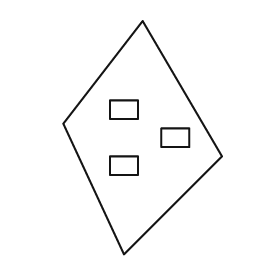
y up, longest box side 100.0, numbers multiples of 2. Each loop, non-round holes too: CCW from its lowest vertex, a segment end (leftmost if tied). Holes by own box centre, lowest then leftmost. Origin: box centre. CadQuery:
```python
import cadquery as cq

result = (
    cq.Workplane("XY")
    .moveTo(-8.0, -50.0)
    .lineTo(34.0, -8.0)
    .lineTo(0.0, 50.0)
    .lineTo(-34.0, 6.0)
    .close()
    .moveTo(-14.0, -16.0)
    .lineTo(-2.0, -16.0)
    .lineTo(-2.0, -8.0)
    .lineTo(-14.0, -8.0)
    .close()
    .moveTo(8.0, -4.0)
    .lineTo(20.0, -4.0)
    .lineTo(20.0, 4.0)
    .lineTo(8.0, 4.0)
    .close()
    .moveTo(-14.0, 8.0)
    .lineTo(-2.0, 8.0)
    .lineTo(-2.0, 16.0)
    .lineTo(-14.0, 16.0)
    .close()
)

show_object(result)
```